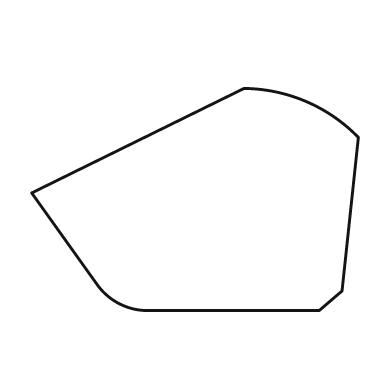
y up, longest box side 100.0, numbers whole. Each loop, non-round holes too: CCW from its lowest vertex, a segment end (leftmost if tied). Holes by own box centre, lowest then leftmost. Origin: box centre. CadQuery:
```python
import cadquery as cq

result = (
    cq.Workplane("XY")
    .moveTo(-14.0, -34.0)
    .lineTo(38.0, -34.0)
    .lineTo(45.0, -28.0)
    .lineTo(50.0, 19.0)
    .threePointArc((34.0, 30.0), (15.0, 34.0))
    .lineTo(-50.0, 2.0)
    .lineTo(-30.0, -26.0)
    .threePointArc((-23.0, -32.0), (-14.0, -34.0))
    .close()
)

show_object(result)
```